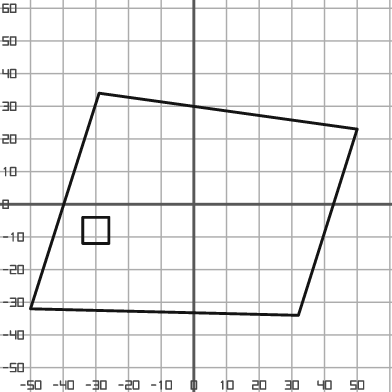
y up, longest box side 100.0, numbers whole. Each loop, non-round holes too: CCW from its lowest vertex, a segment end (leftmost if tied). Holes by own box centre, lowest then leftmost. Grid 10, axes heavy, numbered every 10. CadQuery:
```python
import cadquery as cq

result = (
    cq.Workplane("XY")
    .moveTo(32.0, -34.0)
    .lineTo(50.0, 23.0)
    .lineTo(-29.0, 34.0)
    .lineTo(-50.0, -32.0)
    .close()
    .moveTo(-34.0, -12.0)
    .lineTo(-26.0, -12.0)
    .lineTo(-26.0, -4.0)
    .lineTo(-34.0, -4.0)
    .close()
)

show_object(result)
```